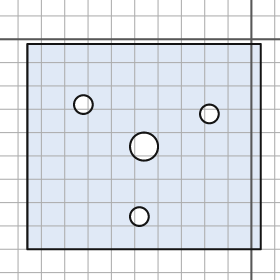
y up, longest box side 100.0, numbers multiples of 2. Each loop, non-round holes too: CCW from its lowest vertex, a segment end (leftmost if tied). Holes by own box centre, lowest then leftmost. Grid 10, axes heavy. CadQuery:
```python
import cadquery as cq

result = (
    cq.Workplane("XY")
    .moveTo(-96.0, -90.0)
    .lineTo(4.0, -90.0)
    .lineTo(4.0, -2.0)
    .lineTo(-96.0, -2.0)
    .close()
    .moveTo(-48.0, -76.0)
    .circle(4.0)
    .moveTo(-46.0, -46.0)
    .circle(6.0)
    .moveTo(-18.0, -32.0)
    .circle(4.0)
    .moveTo(-72.0, -28.0)
    .circle(4.0)
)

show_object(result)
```